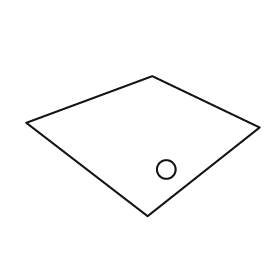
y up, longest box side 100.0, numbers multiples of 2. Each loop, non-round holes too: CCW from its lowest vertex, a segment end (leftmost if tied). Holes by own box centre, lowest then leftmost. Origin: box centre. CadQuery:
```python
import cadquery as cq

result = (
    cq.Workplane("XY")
    .moveTo(2.0, -30.0)
    .lineTo(50.0, 8.0)
    .lineTo(4.0, 30.0)
    .lineTo(-50.0, 10.0)
    .close()
    .moveTo(10.0, -10.0)
    .circle(4.0)
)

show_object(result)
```